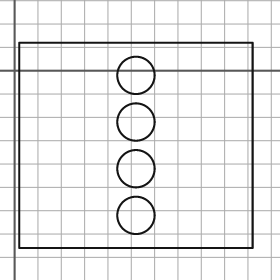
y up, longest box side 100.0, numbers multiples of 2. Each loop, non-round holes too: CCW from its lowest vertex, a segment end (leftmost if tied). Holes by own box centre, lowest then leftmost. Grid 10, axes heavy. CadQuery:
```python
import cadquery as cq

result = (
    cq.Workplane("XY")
    .moveTo(2.0, -76.0)
    .lineTo(102.0, -76.0)
    .lineTo(102.0, 12.0)
    .lineTo(2.0, 12.0)
    .close()
    .moveTo(52.0, -62.0)
    .circle(8.0)
    .moveTo(52.0, -42.0)
    .circle(8.0)
    .moveTo(52.0, -22.0)
    .circle(8.0)
    .moveTo(52.0, -2.0)
    .circle(8.0)
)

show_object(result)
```